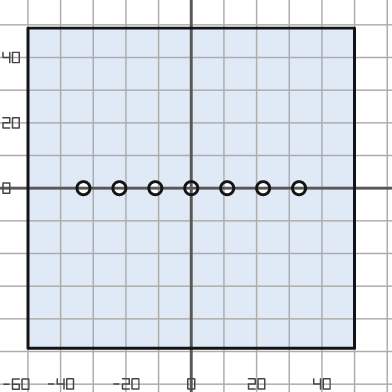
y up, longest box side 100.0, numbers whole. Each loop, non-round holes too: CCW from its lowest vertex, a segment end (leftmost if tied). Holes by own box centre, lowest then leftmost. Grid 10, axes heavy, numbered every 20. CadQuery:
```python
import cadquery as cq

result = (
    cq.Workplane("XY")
    .moveTo(-50.0, -49.0)
    .lineTo(50.0, -49.0)
    .lineTo(50.0, 49.0)
    .lineTo(-50.0, 49.0)
    .close()
    .moveTo(-33.0, 0.0)
    .circle(2.0)
    .moveTo(-22.0, 0.0)
    .circle(2.0)
    .moveTo(-11.0, 0.0)
    .circle(2.0)
    .moveTo(0.0, 0.0)
    .circle(2.0)
    .moveTo(11.0, 0.0)
    .circle(2.0)
    .moveTo(22.0, 0.0)
    .circle(2.0)
    .moveTo(33.0, 0.0)
    .circle(2.0)
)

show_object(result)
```